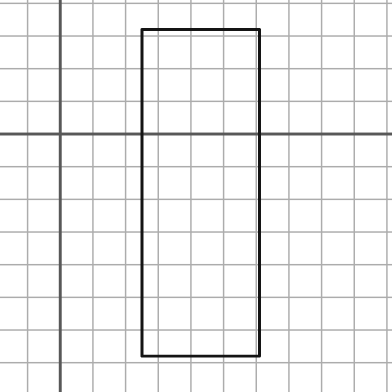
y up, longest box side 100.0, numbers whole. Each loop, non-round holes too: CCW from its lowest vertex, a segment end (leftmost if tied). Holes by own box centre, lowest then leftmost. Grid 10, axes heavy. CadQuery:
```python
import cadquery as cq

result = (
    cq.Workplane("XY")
    .moveTo(25.0, -68.0)
    .lineTo(61.0, -68.0)
    .lineTo(61.0, 32.0)
    .lineTo(25.0, 32.0)
    .close()
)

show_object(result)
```